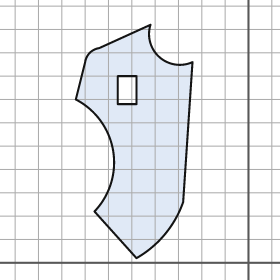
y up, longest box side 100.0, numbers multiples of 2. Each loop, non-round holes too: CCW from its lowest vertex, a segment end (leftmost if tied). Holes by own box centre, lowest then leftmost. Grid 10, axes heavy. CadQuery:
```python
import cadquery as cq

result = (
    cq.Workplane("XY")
    .moveTo(-48.0, 2.0)
    .threePointArc((-36.0, 12.0), (-28.0, 26.0))
    .lineTo(-24.0, 86.0)
    .threePointArc((-38.0, 88.0), (-42.0, 102.0))
    .lineTo(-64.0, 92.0)
    .threePointArc((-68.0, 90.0), (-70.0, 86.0))
    .lineTo(-74.0, 70.0)
    .threePointArc((-58.0, 48.0), (-66.0, 22.0))
    .close()
    .moveTo(-56.0, 68.0)
    .lineTo(-48.0, 68.0)
    .lineTo(-48.0, 80.0)
    .lineTo(-56.0, 80.0)
    .close()
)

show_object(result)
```